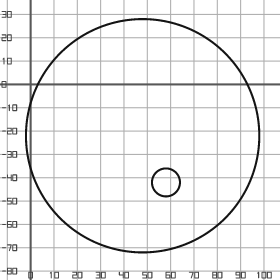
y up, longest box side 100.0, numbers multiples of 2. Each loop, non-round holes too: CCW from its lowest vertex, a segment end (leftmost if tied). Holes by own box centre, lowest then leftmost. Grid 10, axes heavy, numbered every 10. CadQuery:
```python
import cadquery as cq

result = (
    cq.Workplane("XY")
    .moveTo(48.0, -22.0)
    .circle(50.0)
    .moveTo(58.0, -42.0)
    .circle(6.0)
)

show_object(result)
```